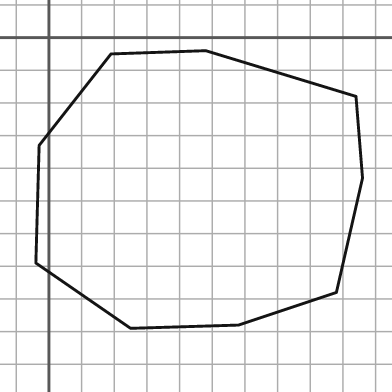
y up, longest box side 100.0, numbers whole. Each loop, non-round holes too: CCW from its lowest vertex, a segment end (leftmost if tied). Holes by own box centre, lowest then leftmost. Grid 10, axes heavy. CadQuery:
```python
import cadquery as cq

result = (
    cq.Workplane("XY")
    .moveTo(25.0, -89.0)
    .lineTo(58.0, -88.0)
    .lineTo(88.0, -78.0)
    .lineTo(96.0, -43.0)
    .lineTo(94.0, -18.0)
    .lineTo(48.0, -4.0)
    .lineTo(19.0, -5.0)
    .lineTo(-3.0, -33.0)
    .lineTo(-4.0, -69.0)
    .close()
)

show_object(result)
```